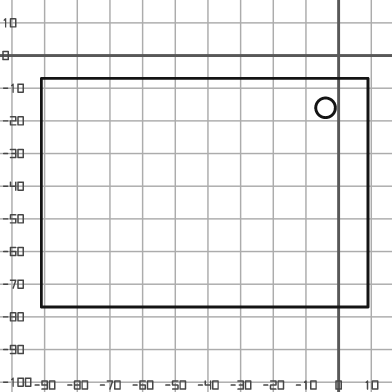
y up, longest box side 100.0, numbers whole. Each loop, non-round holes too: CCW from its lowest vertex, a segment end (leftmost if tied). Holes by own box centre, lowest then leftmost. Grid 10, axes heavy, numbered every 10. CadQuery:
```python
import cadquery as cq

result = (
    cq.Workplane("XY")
    .moveTo(-91.0, -77.0)
    .lineTo(9.0, -77.0)
    .lineTo(9.0, -7.0)
    .lineTo(-91.0, -7.0)
    .close()
    .moveTo(-4.0, -16.0)
    .circle(3.0)
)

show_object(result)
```